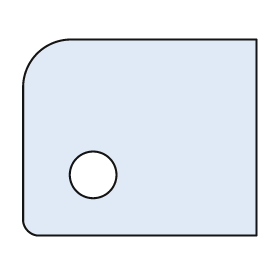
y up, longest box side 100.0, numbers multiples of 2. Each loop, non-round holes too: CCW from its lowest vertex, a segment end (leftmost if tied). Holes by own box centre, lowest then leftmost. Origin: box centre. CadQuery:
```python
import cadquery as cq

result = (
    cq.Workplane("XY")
    .moveTo(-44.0, -42.0)
    .lineTo(50.0, -42.0)
    .lineTo(50.0, 42.0)
    .lineTo(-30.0, 42.0)
    .threePointArc((-44.0, 36.0), (-50.0, 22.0))
    .lineTo(-50.0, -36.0)
    .threePointArc((-48.0, -40.0), (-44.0, -42.0))
    .close()
    .moveTo(-20.0, -16.0)
    .circle(10.0)
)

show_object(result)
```